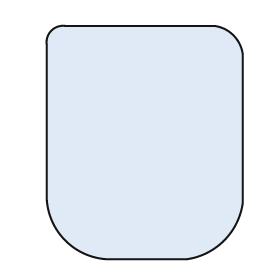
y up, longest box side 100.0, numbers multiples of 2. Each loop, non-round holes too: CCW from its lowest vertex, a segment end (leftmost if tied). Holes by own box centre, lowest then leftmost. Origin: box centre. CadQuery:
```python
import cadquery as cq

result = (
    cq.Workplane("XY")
    .moveTo(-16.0, -50.0)
    .lineTo(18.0, -50.0)
    .threePointArc((34.0, -42.0), (42.0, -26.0))
    .lineTo(42.0, 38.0)
    .threePointArc((38.0, 46.0), (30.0, 50.0))
    .lineTo(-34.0, 50.0)
    .threePointArc((-40.0, 48.0), (-42.0, 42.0))
    .lineTo(-42.0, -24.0)
    .threePointArc((-34.0, -42.0), (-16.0, -50.0))
    .close()
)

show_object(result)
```